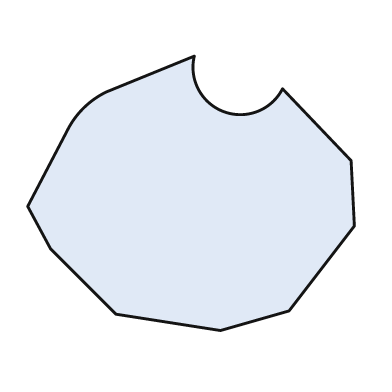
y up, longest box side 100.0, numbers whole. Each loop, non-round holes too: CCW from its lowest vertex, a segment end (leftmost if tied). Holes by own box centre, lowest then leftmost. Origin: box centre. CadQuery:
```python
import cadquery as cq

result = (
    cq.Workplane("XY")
    .moveTo(9.0, -42.0)
    .lineTo(30.0, -36.0)
    .lineTo(50.0, -10.0)
    .lineTo(49.0, 10.0)
    .lineTo(28.0, 32.0)
    .threePointArc((10.0, 25.0), (1.0, 42.0))
    .lineTo(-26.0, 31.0)
    .threePointArc((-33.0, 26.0), (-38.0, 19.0))
    .lineTo(-50.0, -4.0)
    .lineTo(-43.0, -17.0)
    .lineTo(-23.0, -37.0)
    .close()
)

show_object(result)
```